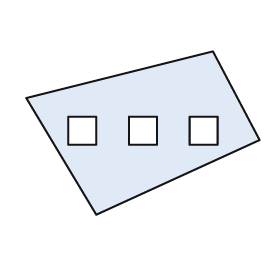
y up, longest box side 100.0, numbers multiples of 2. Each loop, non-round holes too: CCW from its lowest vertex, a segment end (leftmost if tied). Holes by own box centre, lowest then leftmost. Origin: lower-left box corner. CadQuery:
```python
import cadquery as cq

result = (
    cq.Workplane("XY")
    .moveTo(30.0, 0.0)
    .lineTo(100.0, 32.0)
    .lineTo(80.0, 70.0)
    .lineTo(0.0, 50.0)
    .close()
    .moveTo(18.0, 30.0)
    .lineTo(30.0, 30.0)
    .lineTo(30.0, 42.0)
    .lineTo(18.0, 42.0)
    .close()
    .moveTo(44.0, 30.0)
    .lineTo(56.0, 30.0)
    .lineTo(56.0, 42.0)
    .lineTo(44.0, 42.0)
    .close()
    .moveTo(70.0, 30.0)
    .lineTo(82.0, 30.0)
    .lineTo(82.0, 42.0)
    .lineTo(70.0, 42.0)
    .close()
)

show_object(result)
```